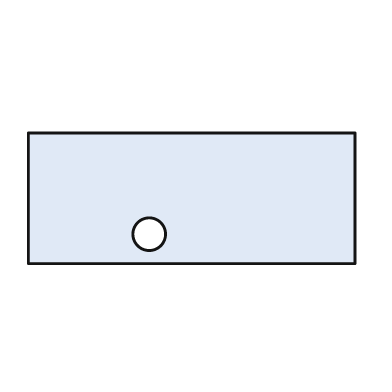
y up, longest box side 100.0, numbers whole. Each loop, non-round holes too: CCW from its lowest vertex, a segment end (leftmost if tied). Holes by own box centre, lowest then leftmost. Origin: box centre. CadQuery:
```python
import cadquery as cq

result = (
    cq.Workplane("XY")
    .moveTo(-50.0, -20.0)
    .lineTo(50.0, -20.0)
    .lineTo(50.0, 20.0)
    .lineTo(-50.0, 20.0)
    .close()
    .moveTo(-13.0, -11.0)
    .circle(5.0)
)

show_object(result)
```